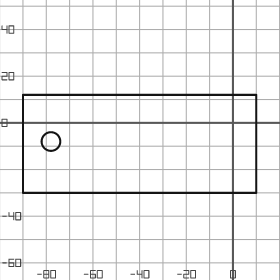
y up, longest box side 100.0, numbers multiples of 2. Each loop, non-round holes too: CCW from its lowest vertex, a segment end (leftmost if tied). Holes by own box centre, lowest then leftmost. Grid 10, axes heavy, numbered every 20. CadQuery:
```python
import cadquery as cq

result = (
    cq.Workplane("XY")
    .moveTo(-90.0, -30.0)
    .lineTo(10.0, -30.0)
    .lineTo(10.0, 12.0)
    .lineTo(-90.0, 12.0)
    .close()
    .moveTo(-78.0, -8.0)
    .circle(4.0)
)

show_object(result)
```